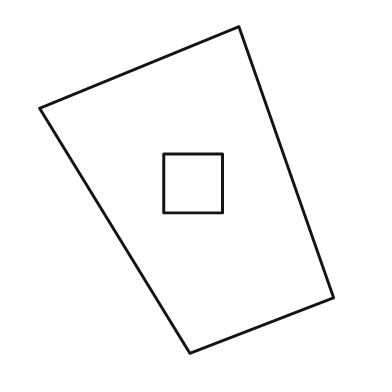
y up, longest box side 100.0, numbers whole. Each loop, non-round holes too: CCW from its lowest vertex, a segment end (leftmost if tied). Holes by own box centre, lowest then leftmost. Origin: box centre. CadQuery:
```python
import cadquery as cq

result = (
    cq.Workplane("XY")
    .moveTo(1.0, -50.0)
    .lineTo(45.0, -33.0)
    .lineTo(16.0, 50.0)
    .lineTo(-45.0, 25.0)
    .close()
    .moveTo(-7.0, -7.0)
    .lineTo(11.0, -7.0)
    .lineTo(11.0, 11.0)
    .lineTo(-7.0, 11.0)
    .close()
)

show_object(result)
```